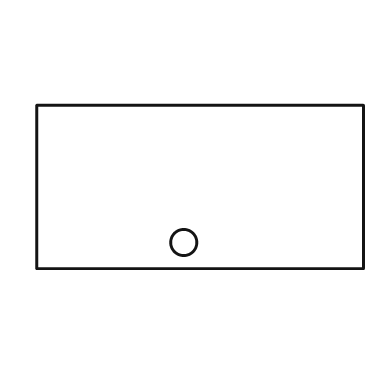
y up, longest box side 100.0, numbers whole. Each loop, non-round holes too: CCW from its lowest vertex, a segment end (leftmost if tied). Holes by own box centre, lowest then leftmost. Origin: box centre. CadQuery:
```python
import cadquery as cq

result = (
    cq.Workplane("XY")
    .moveTo(-50.0, -25.0)
    .lineTo(50.0, -25.0)
    .lineTo(50.0, 25.0)
    .lineTo(-50.0, 25.0)
    .close()
    .moveTo(-5.0, -17.0)
    .circle(4.0)
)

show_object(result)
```